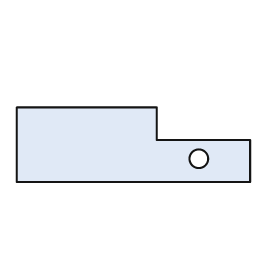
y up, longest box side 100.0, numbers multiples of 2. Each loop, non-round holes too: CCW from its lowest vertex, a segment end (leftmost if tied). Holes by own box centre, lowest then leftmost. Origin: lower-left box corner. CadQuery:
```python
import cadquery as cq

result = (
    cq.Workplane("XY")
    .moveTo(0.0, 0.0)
    .lineTo(100.0, 0.0)
    .lineTo(100.0, 18.0)
    .lineTo(60.0, 18.0)
    .lineTo(60.0, 32.0)
    .lineTo(0.0, 32.0)
    .close()
    .moveTo(78.0, 10.0)
    .circle(4.0)
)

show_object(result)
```